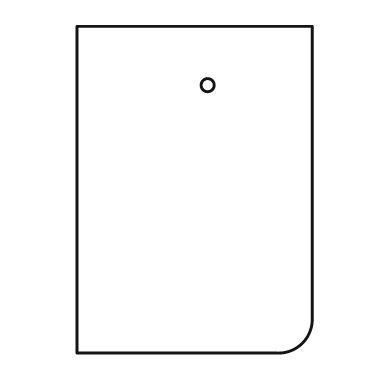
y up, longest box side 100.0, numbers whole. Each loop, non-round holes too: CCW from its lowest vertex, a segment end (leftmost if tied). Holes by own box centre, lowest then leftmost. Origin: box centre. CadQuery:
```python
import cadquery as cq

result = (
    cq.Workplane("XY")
    .moveTo(-36.0, -50.0)
    .lineTo(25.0, -50.0)
    .threePointArc((33.0, -47.0), (36.0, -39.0))
    .lineTo(36.0, 50.0)
    .lineTo(-36.0, 50.0)
    .close()
    .moveTo(4.0, 32.0)
    .circle(2.0)
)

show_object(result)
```